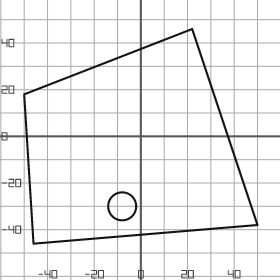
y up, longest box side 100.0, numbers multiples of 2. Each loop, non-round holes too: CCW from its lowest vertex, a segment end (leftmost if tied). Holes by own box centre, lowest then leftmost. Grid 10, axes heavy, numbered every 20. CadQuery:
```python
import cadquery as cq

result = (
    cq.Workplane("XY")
    .moveTo(-46.0, -46.0)
    .lineTo(50.0, -38.0)
    .lineTo(22.0, 46.0)
    .lineTo(-50.0, 18.0)
    .close()
    .moveTo(-8.0, -30.0)
    .circle(6.0)
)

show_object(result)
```